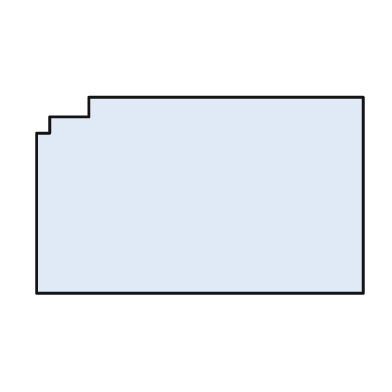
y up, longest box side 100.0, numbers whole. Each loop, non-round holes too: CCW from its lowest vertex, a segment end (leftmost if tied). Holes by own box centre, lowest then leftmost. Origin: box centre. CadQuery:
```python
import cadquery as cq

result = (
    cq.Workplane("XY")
    .moveTo(-50.0, -30.0)
    .lineTo(50.0, -30.0)
    .lineTo(50.0, 30.0)
    .lineTo(-34.0, 30.0)
    .lineTo(-34.0, 24.0)
    .lineTo(-46.0, 24.0)
    .lineTo(-46.0, 19.0)
    .lineTo(-50.0, 19.0)
    .close()
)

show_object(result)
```